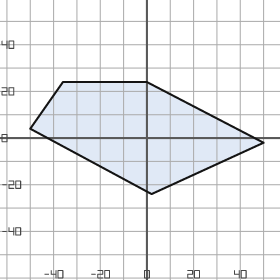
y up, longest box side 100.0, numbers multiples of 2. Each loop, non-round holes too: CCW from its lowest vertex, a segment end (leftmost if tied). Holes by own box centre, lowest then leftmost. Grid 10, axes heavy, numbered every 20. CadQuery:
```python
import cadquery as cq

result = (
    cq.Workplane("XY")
    .moveTo(2.0, -24.0)
    .lineTo(50.0, -2.0)
    .lineTo(0.0, 24.0)
    .lineTo(-36.0, 24.0)
    .lineTo(-50.0, 4.0)
    .close()
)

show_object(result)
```